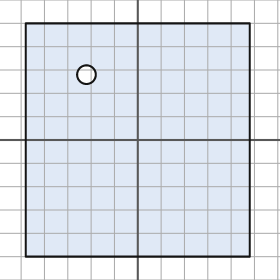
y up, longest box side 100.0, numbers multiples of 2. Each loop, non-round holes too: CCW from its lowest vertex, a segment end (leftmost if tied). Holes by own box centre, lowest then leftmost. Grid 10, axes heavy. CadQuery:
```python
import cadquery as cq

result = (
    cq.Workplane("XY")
    .moveTo(-48.0, -50.0)
    .lineTo(48.0, -50.0)
    .lineTo(48.0, 50.0)
    .lineTo(-48.0, 50.0)
    .close()
    .moveTo(-22.0, 28.0)
    .circle(4.0)
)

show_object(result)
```